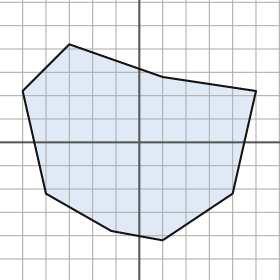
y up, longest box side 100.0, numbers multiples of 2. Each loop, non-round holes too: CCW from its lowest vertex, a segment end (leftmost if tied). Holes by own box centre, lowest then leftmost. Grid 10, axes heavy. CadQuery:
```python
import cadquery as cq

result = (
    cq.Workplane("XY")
    .moveTo(10.0, -42.0)
    .lineTo(40.0, -22.0)
    .lineTo(50.0, 22.0)
    .lineTo(10.0, 28.0)
    .lineTo(-30.0, 42.0)
    .lineTo(-50.0, 22.0)
    .lineTo(-40.0, -22.0)
    .lineTo(-12.0, -38.0)
    .close()
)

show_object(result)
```